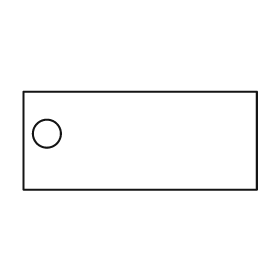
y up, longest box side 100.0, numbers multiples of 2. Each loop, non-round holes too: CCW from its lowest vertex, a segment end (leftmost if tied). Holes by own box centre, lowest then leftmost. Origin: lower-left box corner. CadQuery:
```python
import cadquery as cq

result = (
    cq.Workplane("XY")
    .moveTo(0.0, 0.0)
    .lineTo(100.0, 0.0)
    .lineTo(100.0, 42.0)
    .lineTo(0.0, 42.0)
    .close()
    .moveTo(10.0, 24.0)
    .circle(6.0)
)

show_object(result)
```